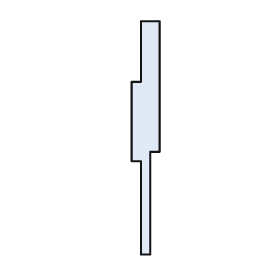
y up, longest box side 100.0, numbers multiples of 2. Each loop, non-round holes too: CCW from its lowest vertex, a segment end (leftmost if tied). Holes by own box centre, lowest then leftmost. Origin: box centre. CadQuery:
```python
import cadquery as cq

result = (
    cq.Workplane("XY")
    .moveTo(-2.0, -50.0)
    .lineTo(2.0, -50.0)
    .lineTo(2.0, -6.0)
    .lineTo(6.0, -6.0)
    .lineTo(6.0, 50.0)
    .lineTo(-2.0, 50.0)
    .lineTo(-2.0, 24.0)
    .lineTo(-6.0, 24.0)
    .lineTo(-6.0, -10.0)
    .lineTo(-2.0, -10.0)
    .close()
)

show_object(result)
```